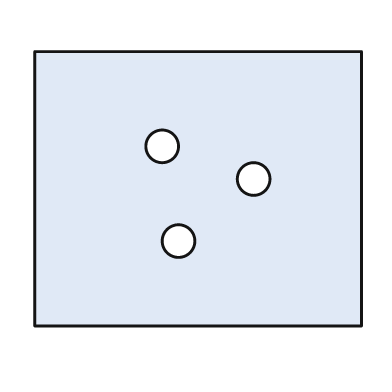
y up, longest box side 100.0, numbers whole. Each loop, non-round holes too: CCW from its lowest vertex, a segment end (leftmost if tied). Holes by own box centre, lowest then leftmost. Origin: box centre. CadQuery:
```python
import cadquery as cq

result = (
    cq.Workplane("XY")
    .moveTo(-50.0, -42.0)
    .lineTo(50.0, -42.0)
    .lineTo(50.0, 42.0)
    .lineTo(-50.0, 42.0)
    .close()
    .moveTo(-6.0, -16.0)
    .circle(5.0)
    .moveTo(17.0, 3.0)
    .circle(5.0)
    .moveTo(-11.0, 13.0)
    .circle(5.0)
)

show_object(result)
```